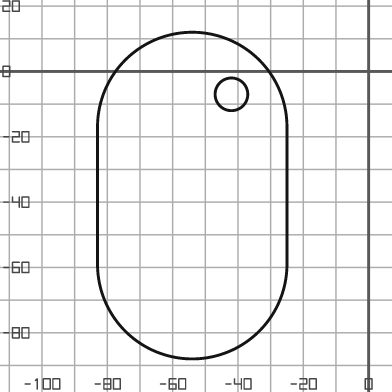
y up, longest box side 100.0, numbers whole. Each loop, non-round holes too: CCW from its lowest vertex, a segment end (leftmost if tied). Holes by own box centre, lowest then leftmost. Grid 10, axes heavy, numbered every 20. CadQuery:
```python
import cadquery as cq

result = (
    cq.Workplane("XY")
    .moveTo(-83.0, -59.0)
    .threePointArc((-54.0, -88.0), (-25.0, -59.0))
    .lineTo(-25.0, -17.0)
    .threePointArc((-54.0, 12.0), (-83.0, -17.0))
    .close()
    .moveTo(-42.0, -7.0)
    .circle(5.0)
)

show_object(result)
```